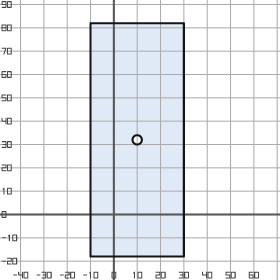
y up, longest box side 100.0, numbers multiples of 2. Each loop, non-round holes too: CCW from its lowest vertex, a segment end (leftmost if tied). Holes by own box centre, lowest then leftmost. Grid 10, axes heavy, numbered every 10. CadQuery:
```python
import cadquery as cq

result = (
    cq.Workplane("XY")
    .moveTo(-10.0, -18.0)
    .lineTo(30.0, -18.0)
    .lineTo(30.0, 82.0)
    .lineTo(-10.0, 82.0)
    .close()
    .moveTo(10.0, 32.0)
    .circle(2.0)
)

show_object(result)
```